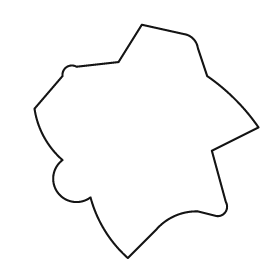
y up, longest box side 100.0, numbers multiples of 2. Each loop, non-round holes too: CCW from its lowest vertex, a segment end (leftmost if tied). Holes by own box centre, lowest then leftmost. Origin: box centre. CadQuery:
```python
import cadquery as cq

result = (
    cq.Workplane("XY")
    .moveTo(-8.0, -50.0)
    .lineTo(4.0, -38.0)
    .threePointArc((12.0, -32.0), (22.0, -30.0))
    .lineTo(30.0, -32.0)
    .threePointArc((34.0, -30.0), (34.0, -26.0))
    .lineTo(28.0, -4.0)
    .lineTo(48.0, 6.0)
    .threePointArc((38.0, 18.0), (26.0, 28.0))
    .lineTo(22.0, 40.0)
    .threePointArc((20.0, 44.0), (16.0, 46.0))
    .lineTo(-2.0, 50.0)
    .lineTo(-12.0, 34.0)
    .lineTo(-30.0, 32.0)
    .threePointArc((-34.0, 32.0), (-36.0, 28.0))
    .lineTo(-48.0, 14.0)
    .threePointArc((-44.0, 2.0), (-36.0, -8.0))
    .threePointArc((-38.0, -22.0), (-24.0, -24.0))
    .threePointArc((-18.0, -38.0), (-8.0, -50.0))
    .close()
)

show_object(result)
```